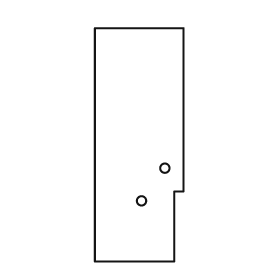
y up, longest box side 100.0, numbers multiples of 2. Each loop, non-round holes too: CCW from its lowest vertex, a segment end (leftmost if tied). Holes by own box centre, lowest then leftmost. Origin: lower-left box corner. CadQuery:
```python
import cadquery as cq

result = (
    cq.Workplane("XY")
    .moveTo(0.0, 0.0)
    .lineTo(34.0, 0.0)
    .lineTo(34.0, 30.0)
    .lineTo(38.0, 30.0)
    .lineTo(38.0, 100.0)
    .lineTo(0.0, 100.0)
    .close()
    .moveTo(20.0, 26.0)
    .circle(2.0)
    .moveTo(30.0, 40.0)
    .circle(2.0)
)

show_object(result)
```